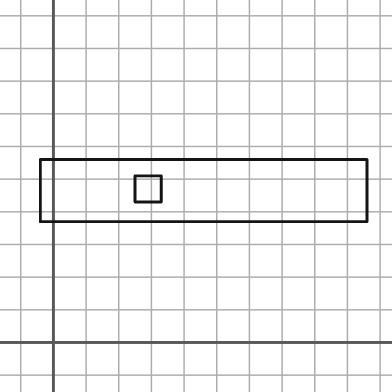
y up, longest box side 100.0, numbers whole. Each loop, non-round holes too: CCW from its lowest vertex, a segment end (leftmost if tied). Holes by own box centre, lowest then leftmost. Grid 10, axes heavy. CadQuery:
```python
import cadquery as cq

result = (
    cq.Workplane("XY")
    .moveTo(-4.0, 37.0)
    .lineTo(96.0, 37.0)
    .lineTo(96.0, 56.0)
    .lineTo(-4.0, 56.0)
    .close()
    .moveTo(25.0, 43.0)
    .lineTo(33.0, 43.0)
    .lineTo(33.0, 51.0)
    .lineTo(25.0, 51.0)
    .close()
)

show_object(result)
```